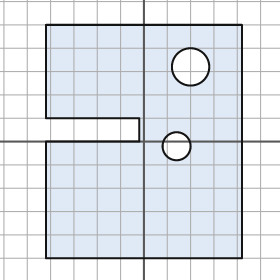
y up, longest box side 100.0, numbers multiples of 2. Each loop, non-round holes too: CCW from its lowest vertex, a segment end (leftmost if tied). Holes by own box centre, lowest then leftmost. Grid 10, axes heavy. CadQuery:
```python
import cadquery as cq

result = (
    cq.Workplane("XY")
    .moveTo(-42.0, -50.0)
    .lineTo(42.0, -50.0)
    .lineTo(42.0, 50.0)
    .lineTo(-42.0, 50.0)
    .lineTo(-42.0, 10.0)
    .lineTo(-2.0, 10.0)
    .lineTo(-2.0, 0.0)
    .lineTo(-42.0, 0.0)
    .close()
    .moveTo(14.0, -2.0)
    .circle(6.0)
    .moveTo(20.0, 32.0)
    .circle(8.0)
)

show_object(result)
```